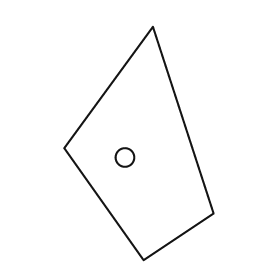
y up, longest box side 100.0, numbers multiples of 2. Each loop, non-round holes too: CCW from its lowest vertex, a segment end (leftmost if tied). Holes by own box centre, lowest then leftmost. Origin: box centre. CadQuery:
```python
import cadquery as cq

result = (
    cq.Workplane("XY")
    .moveTo(2.0, -50.0)
    .lineTo(32.0, -30.0)
    .lineTo(6.0, 50.0)
    .lineTo(-32.0, -2.0)
    .close()
    .moveTo(-6.0, -6.0)
    .circle(4.0)
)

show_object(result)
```